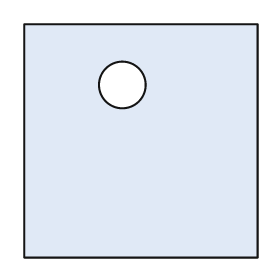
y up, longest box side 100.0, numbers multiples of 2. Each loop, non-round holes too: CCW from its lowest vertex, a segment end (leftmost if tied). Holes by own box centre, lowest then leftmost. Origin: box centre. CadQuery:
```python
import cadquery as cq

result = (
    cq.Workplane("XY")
    .moveTo(-50.0, -50.0)
    .lineTo(50.0, -50.0)
    .lineTo(50.0, 50.0)
    .lineTo(-50.0, 50.0)
    .close()
    .moveTo(-8.0, 24.0)
    .circle(10.0)
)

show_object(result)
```